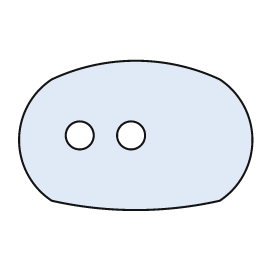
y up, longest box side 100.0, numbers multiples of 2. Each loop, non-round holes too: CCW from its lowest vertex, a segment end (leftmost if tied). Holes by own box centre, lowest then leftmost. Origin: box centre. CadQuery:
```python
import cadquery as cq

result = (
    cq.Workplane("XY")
    .moveTo(-36.0, -28.0)
    .threePointArc((0.0, -32.0), (36.0, -28.0))
    .threePointArc((50.0, -2.0), (36.0, 24.0))
    .threePointArc((0.0, 32.0), (-36.0, 24.0))
    .threePointArc((-50.0, -2.0), (-36.0, -28.0))
    .close()
    .moveTo(-24.0, 0.0)
    .circle(6.0)
    .moveTo(-2.0, 0.0)
    .circle(6.0)
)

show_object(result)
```